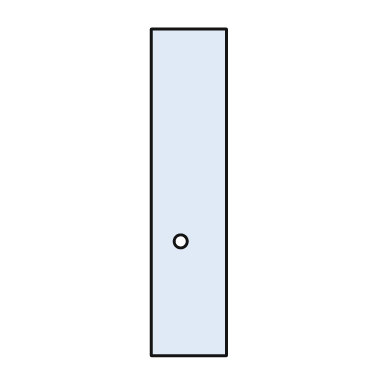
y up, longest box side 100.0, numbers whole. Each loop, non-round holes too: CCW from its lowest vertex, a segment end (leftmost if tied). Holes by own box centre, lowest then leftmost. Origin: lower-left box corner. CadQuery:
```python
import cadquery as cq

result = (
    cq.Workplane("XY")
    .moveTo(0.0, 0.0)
    .lineTo(23.0, 0.0)
    .lineTo(23.0, 100.0)
    .lineTo(0.0, 100.0)
    .close()
    .moveTo(9.0, 35.0)
    .circle(2.0)
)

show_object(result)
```